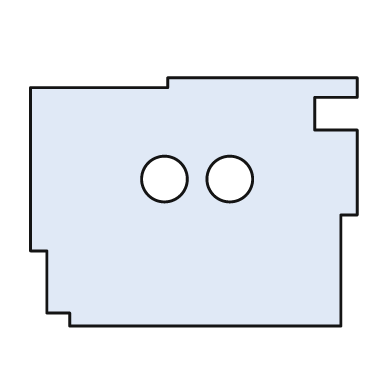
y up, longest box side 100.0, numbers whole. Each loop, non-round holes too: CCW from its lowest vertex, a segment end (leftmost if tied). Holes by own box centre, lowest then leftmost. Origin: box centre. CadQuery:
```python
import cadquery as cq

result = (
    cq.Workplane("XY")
    .moveTo(-38.0, -38.0)
    .lineTo(45.0, -38.0)
    .lineTo(45.0, -4.0)
    .lineTo(50.0, -4.0)
    .lineTo(50.0, 22.0)
    .lineTo(37.0, 22.0)
    .lineTo(37.0, 32.0)
    .lineTo(50.0, 32.0)
    .lineTo(50.0, 38.0)
    .lineTo(-8.0, 38.0)
    .lineTo(-8.0, 35.0)
    .lineTo(-50.0, 35.0)
    .lineTo(-50.0, -15.0)
    .lineTo(-45.0, -15.0)
    .lineTo(-45.0, -34.0)
    .lineTo(-38.0, -34.0)
    .close()
    .moveTo(-9.0, 7.0)
    .circle(7.0)
    .moveTo(11.0, 7.0)
    .circle(7.0)
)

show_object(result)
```